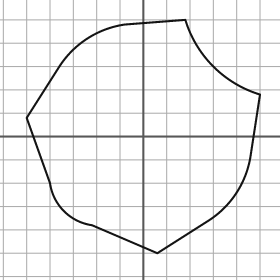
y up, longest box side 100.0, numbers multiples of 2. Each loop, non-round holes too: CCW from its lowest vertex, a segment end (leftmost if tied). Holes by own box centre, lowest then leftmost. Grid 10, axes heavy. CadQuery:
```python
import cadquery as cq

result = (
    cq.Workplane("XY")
    .moveTo(6.0, -50.0)
    .lineTo(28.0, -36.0)
    .threePointArc((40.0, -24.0), (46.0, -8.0))
    .lineTo(50.0, 18.0)
    .threePointArc((30.0, 30.0), (18.0, 50.0))
    .lineTo(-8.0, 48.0)
    .threePointArc((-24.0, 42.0), (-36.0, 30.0))
    .lineTo(-50.0, 8.0)
    .lineTo(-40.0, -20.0)
    .threePointArc((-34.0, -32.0), (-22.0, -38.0))
    .close()
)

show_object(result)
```